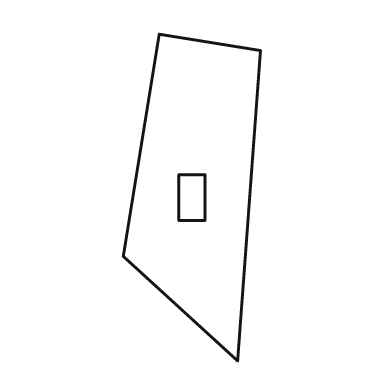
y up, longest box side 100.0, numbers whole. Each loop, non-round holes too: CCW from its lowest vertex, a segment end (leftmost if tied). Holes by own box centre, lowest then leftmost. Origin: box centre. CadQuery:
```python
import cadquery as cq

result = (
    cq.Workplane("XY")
    .moveTo(14.0, -50.0)
    .lineTo(21.0, 45.0)
    .lineTo(-10.0, 50.0)
    .lineTo(-21.0, -18.0)
    .close()
    .moveTo(-4.0, -7.0)
    .lineTo(4.0, -7.0)
    .lineTo(4.0, 7.0)
    .lineTo(-4.0, 7.0)
    .close()
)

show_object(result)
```